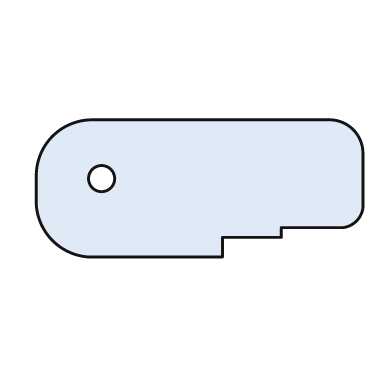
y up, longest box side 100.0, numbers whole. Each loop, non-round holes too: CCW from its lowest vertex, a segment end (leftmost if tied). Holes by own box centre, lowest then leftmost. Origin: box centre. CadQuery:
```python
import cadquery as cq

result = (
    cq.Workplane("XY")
    .moveTo(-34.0, -21.0)
    .lineTo(7.0, -21.0)
    .lineTo(7.0, -15.0)
    .lineTo(25.0, -15.0)
    .lineTo(25.0, -12.0)
    .lineTo(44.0, -12.0)
    .threePointArc((48.0, -10.0), (50.0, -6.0))
    .lineTo(50.0, 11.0)
    .threePointArc((47.0, 18.0), (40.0, 21.0))
    .lineTo(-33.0, 21.0)
    .threePointArc((-45.0, 16.0), (-50.0, 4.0))
    .lineTo(-50.0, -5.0)
    .threePointArc((-45.0, -16.0), (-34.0, -21.0))
    .close()
    .moveTo(-30.0, 3.0)
    .circle(4.0)
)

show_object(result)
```